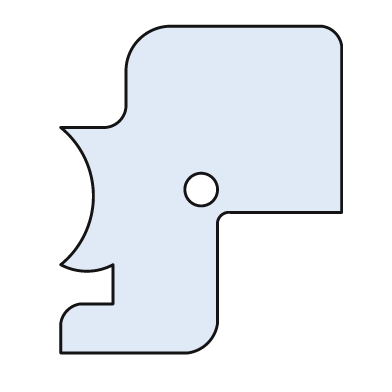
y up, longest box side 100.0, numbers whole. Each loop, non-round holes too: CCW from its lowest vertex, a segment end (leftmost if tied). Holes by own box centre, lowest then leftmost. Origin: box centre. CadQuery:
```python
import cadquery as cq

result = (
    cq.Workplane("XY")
    .moveTo(-43.0, -50.0)
    .lineTo(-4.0, -50.0)
    .threePointArc((2.0, -47.0), (5.0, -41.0))
    .lineTo(5.0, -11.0)
    .threePointArc((6.0, -8.0), (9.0, -7.0))
    .lineTo(43.0, -7.0)
    .lineTo(43.0, 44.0)
    .threePointArc((41.0, 48.0), (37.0, 50.0))
    .lineTo(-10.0, 50.0)
    .threePointArc((-19.0, 46.0), (-23.0, 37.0))
    .lineTo(-23.0, 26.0)
    .threePointArc((-25.0, 21.0), (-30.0, 19.0))
    .lineTo(-43.0, 19.0)
    .threePointArc((-33.0, -2.0), (-43.0, -23.0))
    .threePointArc((-35.0, -25.0), (-27.0, -23.0))
    .lineTo(-27.0, -35.0)
    .lineTo(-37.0, -35.0)
    .threePointArc((-41.0, -37.0), (-43.0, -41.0))
    .close()
    .moveTo(0.0, 0.0)
    .circle(5.0)
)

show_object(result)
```